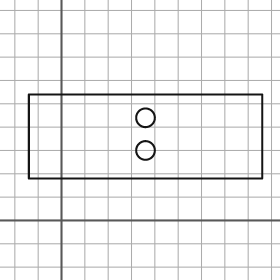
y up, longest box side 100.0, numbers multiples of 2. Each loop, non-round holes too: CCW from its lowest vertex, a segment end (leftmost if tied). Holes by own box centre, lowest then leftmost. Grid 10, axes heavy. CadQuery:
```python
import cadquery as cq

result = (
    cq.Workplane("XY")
    .moveTo(-14.0, 18.0)
    .lineTo(86.0, 18.0)
    .lineTo(86.0, 54.0)
    .lineTo(-14.0, 54.0)
    .close()
    .moveTo(36.0, 30.0)
    .circle(4.0)
    .moveTo(36.0, 44.0)
    .circle(4.0)
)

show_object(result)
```